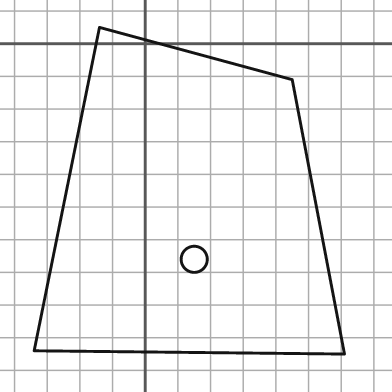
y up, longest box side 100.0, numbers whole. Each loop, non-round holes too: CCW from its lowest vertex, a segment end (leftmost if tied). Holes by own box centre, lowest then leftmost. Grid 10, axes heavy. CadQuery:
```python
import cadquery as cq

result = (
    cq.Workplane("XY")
    .moveTo(61.0, -95.0)
    .lineTo(45.0, -11.0)
    .lineTo(-14.0, 5.0)
    .lineTo(-34.0, -94.0)
    .close()
    .moveTo(15.0, -66.0)
    .circle(4.0)
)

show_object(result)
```